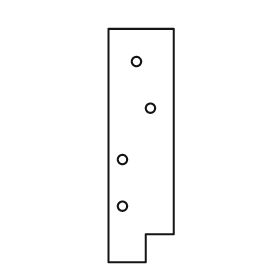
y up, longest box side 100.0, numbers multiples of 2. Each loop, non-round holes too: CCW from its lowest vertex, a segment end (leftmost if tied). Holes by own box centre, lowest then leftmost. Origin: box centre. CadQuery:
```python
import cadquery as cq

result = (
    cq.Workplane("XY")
    .moveTo(-14.0, -50.0)
    .lineTo(2.0, -50.0)
    .lineTo(2.0, -38.0)
    .lineTo(14.0, -38.0)
    .lineTo(14.0, 50.0)
    .lineTo(-14.0, 50.0)
    .close()
    .moveTo(-8.0, -26.0)
    .circle(2.0)
    .moveTo(-8.0, -6.0)
    .circle(2.0)
    .moveTo(4.0, 16.0)
    .circle(2.0)
    .moveTo(-2.0, 36.0)
    .circle(2.0)
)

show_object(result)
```